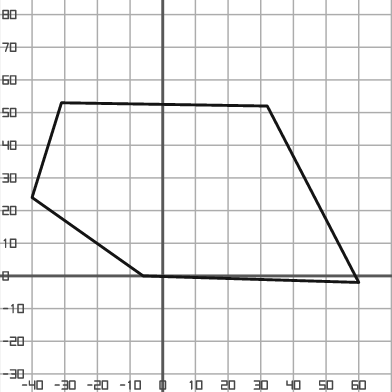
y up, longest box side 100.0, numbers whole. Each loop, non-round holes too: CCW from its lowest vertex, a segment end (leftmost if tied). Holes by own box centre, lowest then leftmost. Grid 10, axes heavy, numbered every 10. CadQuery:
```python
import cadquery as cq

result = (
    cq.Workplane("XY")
    .moveTo(60.0, -2.0)
    .lineTo(32.0, 52.0)
    .lineTo(-31.0, 53.0)
    .lineTo(-40.0, 24.0)
    .lineTo(-6.0, 0.0)
    .close()
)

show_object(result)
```